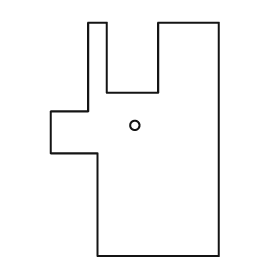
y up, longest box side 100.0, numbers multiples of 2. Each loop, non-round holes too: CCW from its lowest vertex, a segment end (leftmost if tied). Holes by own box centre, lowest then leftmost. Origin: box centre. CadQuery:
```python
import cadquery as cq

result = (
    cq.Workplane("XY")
    .moveTo(-16.0, -50.0)
    .lineTo(36.0, -50.0)
    .lineTo(36.0, 50.0)
    .lineTo(10.0, 50.0)
    .lineTo(10.0, 20.0)
    .lineTo(-12.0, 20.0)
    .lineTo(-12.0, 50.0)
    .lineTo(-20.0, 50.0)
    .lineTo(-20.0, 12.0)
    .lineTo(-36.0, 12.0)
    .lineTo(-36.0, -6.0)
    .lineTo(-16.0, -6.0)
    .close()
    .moveTo(0.0, 6.0)
    .circle(2.0)
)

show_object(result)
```